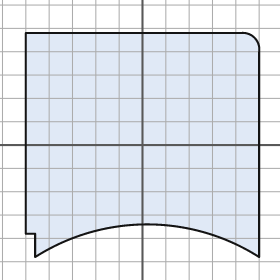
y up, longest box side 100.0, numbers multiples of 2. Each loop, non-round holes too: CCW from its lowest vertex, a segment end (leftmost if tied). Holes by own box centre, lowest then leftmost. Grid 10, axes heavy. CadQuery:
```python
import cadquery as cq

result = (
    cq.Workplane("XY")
    .moveTo(-46.0, -48.0)
    .threePointArc((2.0, -34.0), (50.0, -48.0))
    .lineTo(50.0, 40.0)
    .threePointArc((48.0, 46.0), (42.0, 48.0))
    .lineTo(-50.0, 48.0)
    .lineTo(-50.0, -38.0)
    .lineTo(-46.0, -38.0)
    .close()
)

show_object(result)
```